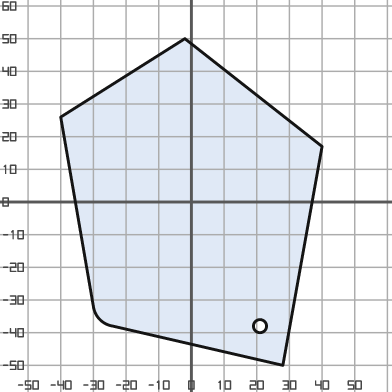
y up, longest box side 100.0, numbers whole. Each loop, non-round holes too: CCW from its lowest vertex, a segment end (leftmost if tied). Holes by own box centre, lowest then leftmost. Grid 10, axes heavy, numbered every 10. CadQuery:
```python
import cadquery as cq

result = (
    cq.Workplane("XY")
    .moveTo(28.0, -50.0)
    .lineTo(40.0, 17.0)
    .lineTo(-2.0, 50.0)
    .lineTo(-40.0, 26.0)
    .lineTo(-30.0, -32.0)
    .threePointArc((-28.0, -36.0), (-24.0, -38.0))
    .close()
    .moveTo(21.0, -38.0)
    .circle(2.0)
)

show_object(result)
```